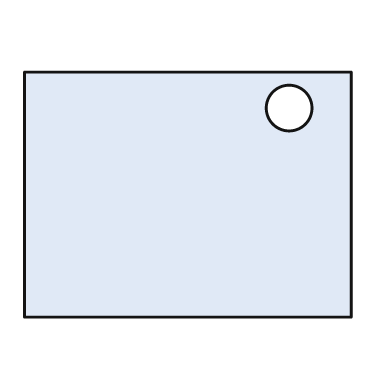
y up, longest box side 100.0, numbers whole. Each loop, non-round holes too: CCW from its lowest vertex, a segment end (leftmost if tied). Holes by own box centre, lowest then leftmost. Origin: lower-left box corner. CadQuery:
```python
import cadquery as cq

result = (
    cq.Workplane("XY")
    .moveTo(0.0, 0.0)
    .lineTo(100.0, 0.0)
    .lineTo(100.0, 75.0)
    .lineTo(0.0, 75.0)
    .close()
    .moveTo(81.0, 64.0)
    .circle(7.0)
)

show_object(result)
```